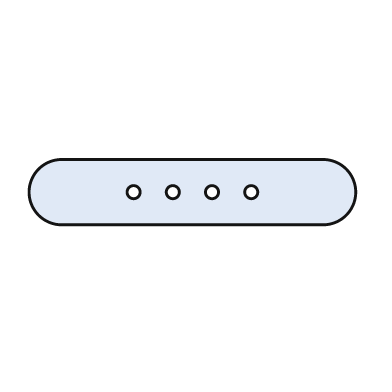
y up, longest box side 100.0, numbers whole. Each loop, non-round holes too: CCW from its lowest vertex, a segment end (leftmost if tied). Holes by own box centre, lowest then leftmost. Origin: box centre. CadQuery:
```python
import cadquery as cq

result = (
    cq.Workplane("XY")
    .moveTo(-40.0, -10.0)
    .lineTo(40.0, -10.0)
    .threePointArc((50.0, 0.0), (40.0, 10.0))
    .lineTo(-40.0, 10.0)
    .threePointArc((-50.0, 0.0), (-40.0, -10.0))
    .close()
    .moveTo(-18.0, 0.0)
    .circle(2.0)
    .moveTo(-6.0, 0.0)
    .circle(2.0)
    .moveTo(6.0, 0.0)
    .circle(2.0)
    .moveTo(18.0, 0.0)
    .circle(2.0)
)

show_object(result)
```